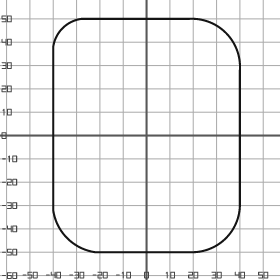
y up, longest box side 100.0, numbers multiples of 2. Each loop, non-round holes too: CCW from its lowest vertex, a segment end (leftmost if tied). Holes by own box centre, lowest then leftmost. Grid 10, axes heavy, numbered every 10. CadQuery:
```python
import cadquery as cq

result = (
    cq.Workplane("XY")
    .moveTo(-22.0, -50.0)
    .lineTo(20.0, -50.0)
    .threePointArc((34.0, -44.0), (40.0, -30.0))
    .lineTo(40.0, 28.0)
    .threePointArc((34.0, 44.0), (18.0, 50.0))
    .lineTo(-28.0, 50.0)
    .threePointArc((-36.0, 46.0), (-40.0, 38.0))
    .lineTo(-40.0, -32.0)
    .threePointArc((-34.0, -44.0), (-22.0, -50.0))
    .close()
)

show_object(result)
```